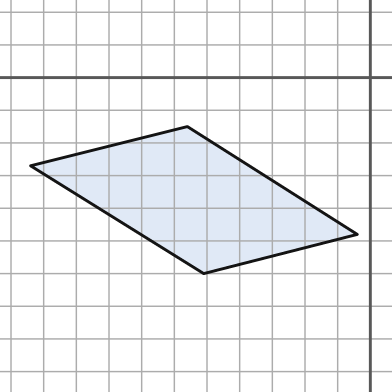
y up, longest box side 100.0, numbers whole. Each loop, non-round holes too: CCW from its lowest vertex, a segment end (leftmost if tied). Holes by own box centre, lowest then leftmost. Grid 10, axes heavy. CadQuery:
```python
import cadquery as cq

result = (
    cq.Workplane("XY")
    .moveTo(-51.0, -60.0)
    .lineTo(-4.0, -48.0)
    .lineTo(-56.0, -15.0)
    .lineTo(-104.0, -27.0)
    .close()
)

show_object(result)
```